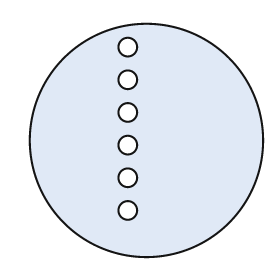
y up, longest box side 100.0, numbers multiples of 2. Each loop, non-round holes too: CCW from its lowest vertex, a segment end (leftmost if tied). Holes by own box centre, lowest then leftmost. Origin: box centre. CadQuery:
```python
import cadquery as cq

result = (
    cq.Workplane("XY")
    .moveTo(0.0, 0.0)
    .circle(50.0)
    .moveTo(-8.0, -30.0)
    .circle(4.0)
    .moveTo(-8.0, -16.0)
    .circle(4.0)
    .moveTo(-8.0, -2.0)
    .circle(4.0)
    .moveTo(-8.0, 12.0)
    .circle(4.0)
    .moveTo(-8.0, 26.0)
    .circle(4.0)
    .moveTo(-8.0, 40.0)
    .circle(4.0)
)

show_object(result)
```